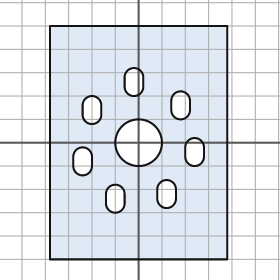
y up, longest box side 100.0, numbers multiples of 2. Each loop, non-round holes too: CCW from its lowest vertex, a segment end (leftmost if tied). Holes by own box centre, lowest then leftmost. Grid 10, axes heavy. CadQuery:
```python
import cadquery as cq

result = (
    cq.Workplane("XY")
    .moveTo(-38.0, -50.0)
    .lineTo(38.0, -50.0)
    .lineTo(38.0, 50.0)
    .lineTo(-38.0, 50.0)
    .close()
    .moveTo(-14.0, -26.0)
    .threePointArc((-10.0, -30.0), (-6.0, -26.0))
    .lineTo(-6.0, -22.0)
    .threePointArc((-10.0, -18.0), (-14.0, -22.0))
    .close()
    .moveTo(8.0, -24.0)
    .threePointArc((12.0, -28.0), (16.0, -24.0))
    .lineTo(16.0, -20.0)
    .threePointArc((12.0, -16.0), (8.0, -20.0))
    .close()
    .moveTo(-28.0, -10.0)
    .threePointArc((-24.0, -14.0), (-20.0, -10.0))
    .lineTo(-20.0, -6.0)
    .threePointArc((-24.0, -2.0), (-28.0, -6.0))
    .close()
    .moveTo(20.0, -6.0)
    .threePointArc((24.0, -10.0), (28.0, -6.0))
    .lineTo(28.0, -2.0)
    .threePointArc((24.0, 2.0), (20.0, -2.0))
    .close()
    .moveTo(0.0, 0.0)
    .circle(10.0)
    .moveTo(-24.0, 12.0)
    .threePointArc((-20.0, 8.0), (-16.0, 12.0))
    .lineTo(-16.0, 16.0)
    .threePointArc((-20.0, 20.0), (-24.0, 16.0))
    .close()
    .moveTo(14.0, 14.0)
    .threePointArc((18.0, 10.0), (22.0, 14.0))
    .lineTo(22.0, 18.0)
    .threePointArc((18.0, 22.0), (14.0, 18.0))
    .close()
    .moveTo(-6.0, 24.0)
    .threePointArc((-2.0, 20.0), (2.0, 24.0))
    .lineTo(2.0, 28.0)
    .threePointArc((-2.0, 32.0), (-6.0, 28.0))
    .close()
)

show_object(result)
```